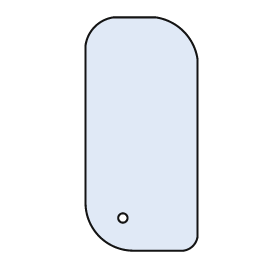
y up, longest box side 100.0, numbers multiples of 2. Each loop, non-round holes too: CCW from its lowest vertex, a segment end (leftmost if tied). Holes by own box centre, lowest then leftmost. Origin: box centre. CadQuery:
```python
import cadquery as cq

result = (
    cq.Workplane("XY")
    .moveTo(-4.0, -50.0)
    .lineTo(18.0, -50.0)
    .threePointArc((22.0, -48.0), (24.0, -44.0))
    .lineTo(24.0, 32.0)
    .threePointArc((18.0, 44.0), (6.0, 50.0))
    .lineTo(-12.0, 50.0)
    .threePointArc((-20.0, 46.0), (-24.0, 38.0))
    .lineTo(-24.0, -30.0)
    .threePointArc((-18.0, -44.0), (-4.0, -50.0))
    .close()
    .moveTo(-8.0, -36.0)
    .circle(2.0)
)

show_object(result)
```